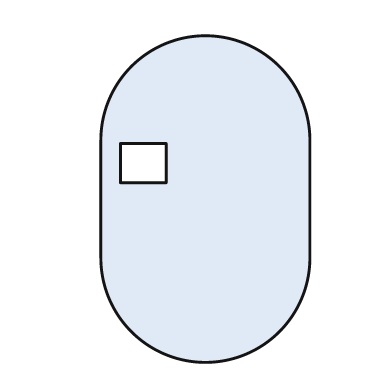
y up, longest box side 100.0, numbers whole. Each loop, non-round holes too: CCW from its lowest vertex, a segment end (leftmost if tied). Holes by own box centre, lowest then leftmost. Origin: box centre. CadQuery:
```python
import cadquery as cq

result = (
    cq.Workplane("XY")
    .moveTo(-32.0, -18.0)
    .threePointArc((0.0, -50.0), (32.0, -18.0))
    .lineTo(32.0, 18.0)
    .threePointArc((0.0, 50.0), (-32.0, 18.0))
    .close()
    .moveTo(-26.0, 5.0)
    .lineTo(-12.0, 5.0)
    .lineTo(-12.0, 17.0)
    .lineTo(-26.0, 17.0)
    .close()
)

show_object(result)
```